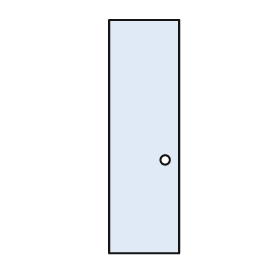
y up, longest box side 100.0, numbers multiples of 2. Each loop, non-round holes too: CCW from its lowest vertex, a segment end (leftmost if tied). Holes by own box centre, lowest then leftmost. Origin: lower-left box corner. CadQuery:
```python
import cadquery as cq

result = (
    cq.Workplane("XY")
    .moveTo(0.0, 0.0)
    .lineTo(30.0, 0.0)
    .lineTo(30.0, 100.0)
    .lineTo(0.0, 100.0)
    .close()
    .moveTo(24.0, 40.0)
    .circle(2.0)
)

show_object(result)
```